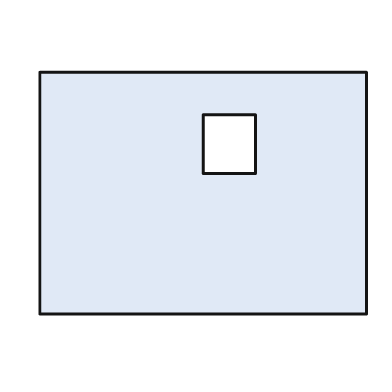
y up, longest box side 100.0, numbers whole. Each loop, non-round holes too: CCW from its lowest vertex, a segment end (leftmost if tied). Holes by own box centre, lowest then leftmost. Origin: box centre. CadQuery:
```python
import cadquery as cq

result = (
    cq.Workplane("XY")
    .moveTo(-50.0, -37.0)
    .lineTo(50.0, -37.0)
    .lineTo(50.0, 37.0)
    .lineTo(-50.0, 37.0)
    .close()
    .moveTo(0.0, 6.0)
    .lineTo(16.0, 6.0)
    .lineTo(16.0, 24.0)
    .lineTo(0.0, 24.0)
    .close()
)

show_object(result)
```